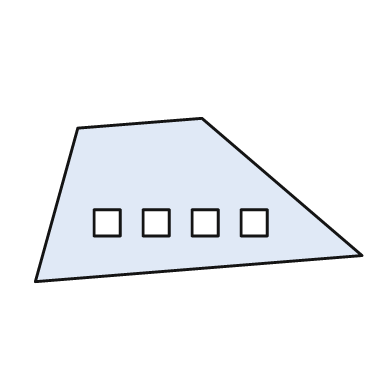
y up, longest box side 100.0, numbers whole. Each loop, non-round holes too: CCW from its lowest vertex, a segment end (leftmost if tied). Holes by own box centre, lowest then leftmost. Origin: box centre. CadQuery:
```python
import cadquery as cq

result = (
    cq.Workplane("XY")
    .moveTo(-50.0, -25.0)
    .lineTo(50.0, -17.0)
    .lineTo(1.0, 25.0)
    .lineTo(-37.0, 22.0)
    .close()
    .moveTo(-32.0, -11.0)
    .lineTo(-24.0, -11.0)
    .lineTo(-24.0, -3.0)
    .lineTo(-32.0, -3.0)
    .close()
    .moveTo(-17.0, -11.0)
    .lineTo(-9.0, -11.0)
    .lineTo(-9.0, -3.0)
    .lineTo(-17.0, -3.0)
    .close()
    .moveTo(-2.0, -11.0)
    .lineTo(6.0, -11.0)
    .lineTo(6.0, -3.0)
    .lineTo(-2.0, -3.0)
    .close()
    .moveTo(13.0, -11.0)
    .lineTo(21.0, -11.0)
    .lineTo(21.0, -3.0)
    .lineTo(13.0, -3.0)
    .close()
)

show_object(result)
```